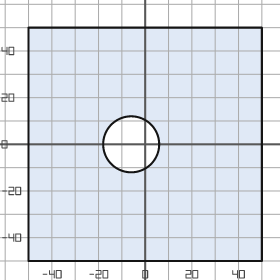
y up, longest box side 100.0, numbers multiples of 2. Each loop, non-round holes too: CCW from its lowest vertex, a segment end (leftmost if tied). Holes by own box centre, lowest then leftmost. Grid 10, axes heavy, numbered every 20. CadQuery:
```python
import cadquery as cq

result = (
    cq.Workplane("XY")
    .moveTo(-50.0, -50.0)
    .lineTo(50.0, -50.0)
    .lineTo(50.0, 50.0)
    .lineTo(-50.0, 50.0)
    .close()
    .moveTo(-6.0, 0.0)
    .circle(12.0)
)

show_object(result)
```